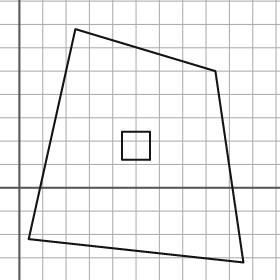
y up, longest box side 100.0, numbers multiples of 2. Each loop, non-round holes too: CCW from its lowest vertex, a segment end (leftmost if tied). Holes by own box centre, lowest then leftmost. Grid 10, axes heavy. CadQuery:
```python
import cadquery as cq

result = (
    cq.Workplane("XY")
    .moveTo(96.0, -32.0)
    .lineTo(84.0, 50.0)
    .lineTo(24.0, 68.0)
    .lineTo(4.0, -22.0)
    .close()
    .moveTo(44.0, 12.0)
    .lineTo(56.0, 12.0)
    .lineTo(56.0, 24.0)
    .lineTo(44.0, 24.0)
    .close()
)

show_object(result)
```